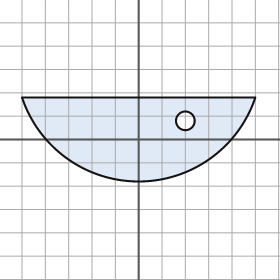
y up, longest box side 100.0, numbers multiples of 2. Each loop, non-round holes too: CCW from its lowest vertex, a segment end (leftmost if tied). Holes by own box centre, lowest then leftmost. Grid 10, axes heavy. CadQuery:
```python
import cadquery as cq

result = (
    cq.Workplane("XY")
    .moveTo(-50.0, 18.0)
    .threePointArc((0.0, -18.0), (50.0, 18.0))
    .close()
    .moveTo(20.0, 8.0)
    .circle(4.0)
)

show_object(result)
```